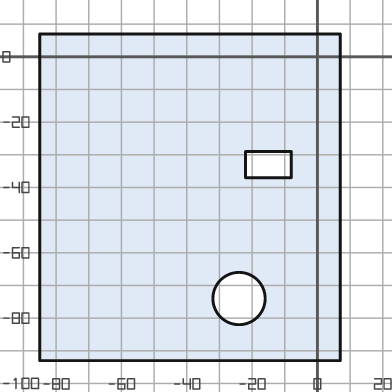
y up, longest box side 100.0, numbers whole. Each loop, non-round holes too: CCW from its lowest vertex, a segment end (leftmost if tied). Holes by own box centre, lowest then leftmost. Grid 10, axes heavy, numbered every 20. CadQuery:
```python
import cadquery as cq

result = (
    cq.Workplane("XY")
    .moveTo(-85.0, -93.0)
    .lineTo(7.0, -93.0)
    .lineTo(7.0, 7.0)
    .lineTo(-85.0, 7.0)
    .close()
    .moveTo(-24.0, -74.0)
    .circle(8.0)
    .moveTo(-22.0, -37.0)
    .lineTo(-8.0, -37.0)
    .lineTo(-8.0, -29.0)
    .lineTo(-22.0, -29.0)
    .close()
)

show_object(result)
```